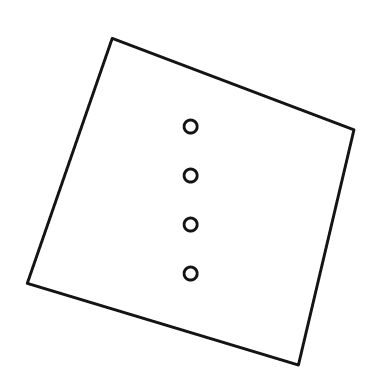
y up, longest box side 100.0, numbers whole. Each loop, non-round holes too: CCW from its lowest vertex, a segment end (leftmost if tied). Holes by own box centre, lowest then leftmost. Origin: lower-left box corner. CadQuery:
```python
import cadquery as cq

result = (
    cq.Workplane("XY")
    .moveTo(83.0, 0.0)
    .lineTo(100.0, 72.0)
    .lineTo(26.0, 100.0)
    .lineTo(0.0, 25.0)
    .close()
    .moveTo(50.0, 28.0)
    .circle(2.0)
    .moveTo(50.0, 43.0)
    .circle(2.0)
    .moveTo(50.0, 58.0)
    .circle(2.0)
    .moveTo(50.0, 73.0)
    .circle(2.0)
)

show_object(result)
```